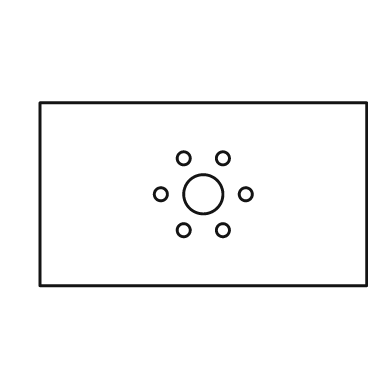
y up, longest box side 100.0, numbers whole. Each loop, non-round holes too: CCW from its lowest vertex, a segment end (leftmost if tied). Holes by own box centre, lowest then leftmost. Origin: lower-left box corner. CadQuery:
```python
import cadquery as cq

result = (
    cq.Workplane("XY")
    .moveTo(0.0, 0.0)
    .lineTo(100.0, 0.0)
    .lineTo(100.0, 56.0)
    .lineTo(0.0, 56.0)
    .close()
    .moveTo(44.0, 17.0)
    .circle(2.0)
    .moveTo(56.0, 17.0)
    .circle(2.0)
    .moveTo(37.0, 28.0)
    .circle(2.0)
    .moveTo(50.0, 28.0)
    .circle(6.0)
    .moveTo(63.0, 28.0)
    .circle(2.0)
    .moveTo(44.0, 39.0)
    .circle(2.0)
    .moveTo(56.0, 39.0)
    .circle(2.0)
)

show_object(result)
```